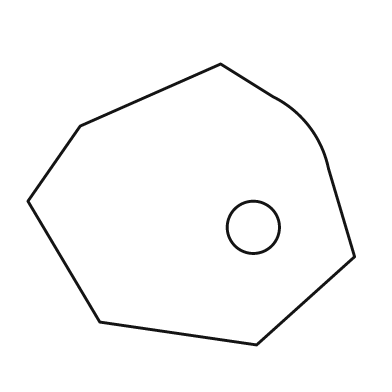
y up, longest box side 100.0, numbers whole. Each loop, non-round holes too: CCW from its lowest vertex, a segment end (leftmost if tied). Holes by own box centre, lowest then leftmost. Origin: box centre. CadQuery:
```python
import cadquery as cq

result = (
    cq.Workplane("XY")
    .moveTo(20.0, -43.0)
    .lineTo(50.0, -16.0)
    .lineTo(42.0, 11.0)
    .threePointArc((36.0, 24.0), (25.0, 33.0))
    .lineTo(9.0, 43.0)
    .lineTo(-34.0, 24.0)
    .lineTo(-50.0, 1.0)
    .lineTo(-28.0, -36.0)
    .close()
    .moveTo(19.0, -7.0)
    .circle(8.0)
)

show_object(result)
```